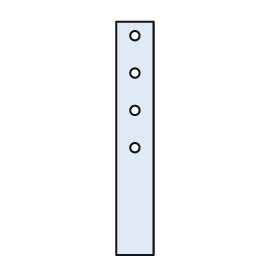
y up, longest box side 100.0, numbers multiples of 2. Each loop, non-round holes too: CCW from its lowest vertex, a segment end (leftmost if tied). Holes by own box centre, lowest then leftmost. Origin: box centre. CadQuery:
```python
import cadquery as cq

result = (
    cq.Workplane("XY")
    .moveTo(-8.0, -50.0)
    .lineTo(8.0, -50.0)
    .lineTo(8.0, 50.0)
    .lineTo(-8.0, 50.0)
    .close()
    .moveTo(0.0, -4.0)
    .circle(2.0)
    .moveTo(0.0, 12.0)
    .circle(2.0)
    .moveTo(0.0, 28.0)
    .circle(2.0)
    .moveTo(0.0, 44.0)
    .circle(2.0)
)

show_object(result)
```